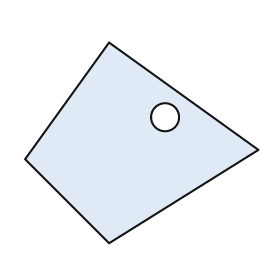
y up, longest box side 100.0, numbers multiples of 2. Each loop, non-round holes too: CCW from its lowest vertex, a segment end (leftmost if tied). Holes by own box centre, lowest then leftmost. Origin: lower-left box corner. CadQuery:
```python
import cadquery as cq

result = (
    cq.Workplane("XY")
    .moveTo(36.0, 0.0)
    .lineTo(100.0, 40.0)
    .lineTo(36.0, 86.0)
    .lineTo(0.0, 36.0)
    .close()
    .moveTo(60.0, 54.0)
    .circle(6.0)
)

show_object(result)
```